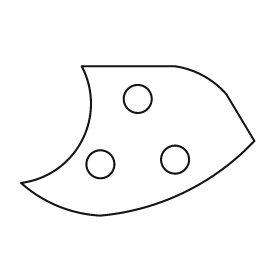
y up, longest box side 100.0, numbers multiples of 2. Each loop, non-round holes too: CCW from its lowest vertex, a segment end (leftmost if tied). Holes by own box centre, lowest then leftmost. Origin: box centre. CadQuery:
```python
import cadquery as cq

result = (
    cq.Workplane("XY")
    .moveTo(-16.0, -32.0)
    .threePointArc((20.0, -22.0), (50.0, 0.0))
    .lineTo(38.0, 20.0)
    .threePointArc((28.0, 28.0), (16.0, 32.0))
    .lineTo(-24.0, 32.0)
    .threePointArc((-24.0, 0.0), (-50.0, -18.0))
    .threePointArc((-34.0, -28.0), (-16.0, -32.0))
    .close()
    .moveTo(-16.0, -10.0)
    .circle(6.0)
    .moveTo(16.0, -8.0)
    .circle(6.0)
    .moveTo(0.0, 18.0)
    .circle(6.0)
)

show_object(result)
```